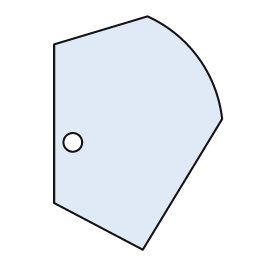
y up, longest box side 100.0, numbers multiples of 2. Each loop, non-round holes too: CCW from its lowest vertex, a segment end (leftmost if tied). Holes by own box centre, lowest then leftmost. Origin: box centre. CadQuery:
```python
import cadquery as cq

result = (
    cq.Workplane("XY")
    .moveTo(2.0, -50.0)
    .lineTo(36.0, 6.0)
    .threePointArc((26.0, 32.0), (4.0, 50.0))
    .lineTo(-36.0, 38.0)
    .lineTo(-36.0, -30.0)
    .close()
    .moveTo(-28.0, -4.0)
    .circle(4.0)
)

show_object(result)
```